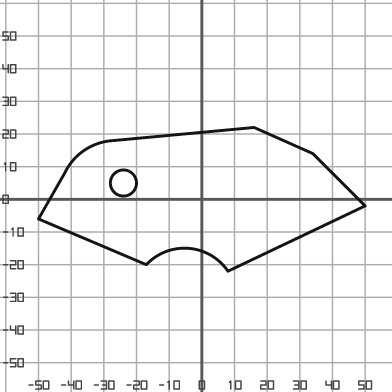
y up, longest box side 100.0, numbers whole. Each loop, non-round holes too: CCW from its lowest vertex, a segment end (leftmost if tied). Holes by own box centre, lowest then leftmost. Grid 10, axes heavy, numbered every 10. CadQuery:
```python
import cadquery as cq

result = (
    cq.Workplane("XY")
    .moveTo(8.0, -22.0)
    .lineTo(50.0, -2.0)
    .lineTo(34.0, 14.0)
    .lineTo(16.0, 22.0)
    .lineTo(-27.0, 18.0)
    .threePointArc((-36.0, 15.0), (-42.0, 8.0))
    .lineTo(-50.0, -6.0)
    .lineTo(-17.0, -20.0)
    .threePointArc((-4.0, -15.0), (8.0, -22.0))
    .close()
    .moveTo(-24.0, 5.0)
    .circle(4.0)
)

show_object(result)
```